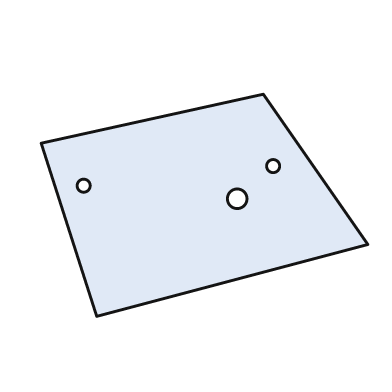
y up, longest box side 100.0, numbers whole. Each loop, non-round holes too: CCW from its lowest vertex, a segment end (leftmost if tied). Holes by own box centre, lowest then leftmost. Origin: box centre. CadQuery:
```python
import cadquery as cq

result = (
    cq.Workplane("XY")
    .moveTo(-33.0, -34.0)
    .lineTo(50.0, -12.0)
    .lineTo(18.0, 34.0)
    .lineTo(-50.0, 19.0)
    .close()
    .moveTo(10.0, 2.0)
    .circle(3.0)
    .moveTo(-37.0, 6.0)
    .circle(2.0)
    .moveTo(21.0, 12.0)
    .circle(2.0)
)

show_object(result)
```